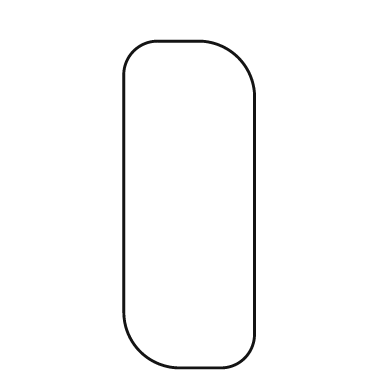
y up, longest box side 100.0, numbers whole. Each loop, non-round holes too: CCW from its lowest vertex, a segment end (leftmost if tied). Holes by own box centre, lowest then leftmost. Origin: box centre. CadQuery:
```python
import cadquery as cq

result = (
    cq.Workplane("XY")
    .moveTo(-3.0, -50.0)
    .lineTo(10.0, -50.0)
    .threePointArc((17.0, -47.0), (20.0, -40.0))
    .lineTo(20.0, 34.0)
    .threePointArc((15.0, 45.0), (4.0, 50.0))
    .lineTo(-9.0, 50.0)
    .threePointArc((-17.0, 47.0), (-20.0, 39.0))
    .lineTo(-20.0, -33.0)
    .threePointArc((-15.0, -45.0), (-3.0, -50.0))
    .close()
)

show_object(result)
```